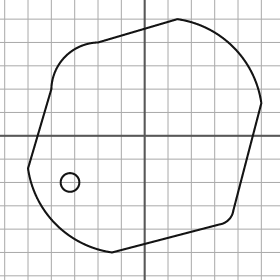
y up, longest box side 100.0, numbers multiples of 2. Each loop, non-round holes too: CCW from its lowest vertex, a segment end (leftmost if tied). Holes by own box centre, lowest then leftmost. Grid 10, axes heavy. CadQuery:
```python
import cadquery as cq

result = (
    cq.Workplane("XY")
    .moveTo(-14.0, -50.0)
    .lineTo(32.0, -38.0)
    .threePointArc((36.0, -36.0), (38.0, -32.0))
    .lineTo(50.0, 14.0)
    .threePointArc((38.0, 38.0), (14.0, 50.0))
    .lineTo(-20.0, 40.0)
    .threePointArc((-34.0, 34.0), (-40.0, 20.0))
    .lineTo(-50.0, -14.0)
    .threePointArc((-38.0, -38.0), (-14.0, -50.0))
    .close()
    .moveTo(-32.0, -20.0)
    .circle(4.0)
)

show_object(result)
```